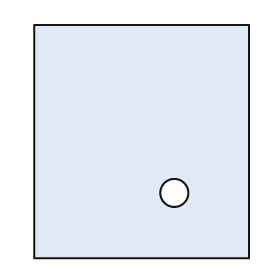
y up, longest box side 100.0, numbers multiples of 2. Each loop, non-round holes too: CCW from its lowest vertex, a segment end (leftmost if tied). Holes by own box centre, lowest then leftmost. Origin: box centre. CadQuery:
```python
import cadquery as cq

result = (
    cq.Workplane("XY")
    .moveTo(-46.0, -50.0)
    .lineTo(46.0, -50.0)
    .lineTo(46.0, 50.0)
    .lineTo(-46.0, 50.0)
    .close()
    .moveTo(14.0, -22.0)
    .circle(6.0)
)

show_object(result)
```